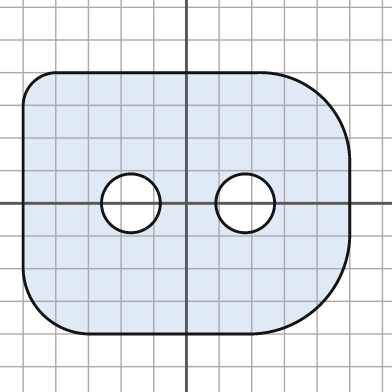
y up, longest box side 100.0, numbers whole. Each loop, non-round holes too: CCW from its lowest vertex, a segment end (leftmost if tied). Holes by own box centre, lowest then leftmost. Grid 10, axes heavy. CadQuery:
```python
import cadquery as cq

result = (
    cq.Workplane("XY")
    .moveTo(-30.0, -40.0)
    .lineTo(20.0, -40.0)
    .threePointArc((41.0, -31.0), (50.0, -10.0))
    .lineTo(50.0, 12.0)
    .threePointArc((42.0, 32.0), (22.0, 40.0))
    .lineTo(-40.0, 40.0)
    .threePointArc((-47.0, 37.0), (-50.0, 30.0))
    .lineTo(-50.0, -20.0)
    .threePointArc((-44.0, -34.0), (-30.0, -40.0))
    .close()
    .moveTo(-17.0, 0.0)
    .circle(9.0)
    .moveTo(18.0, 0.0)
    .circle(9.0)
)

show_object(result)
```